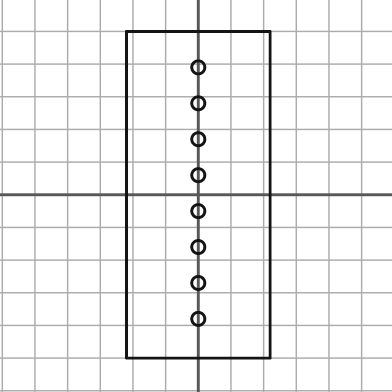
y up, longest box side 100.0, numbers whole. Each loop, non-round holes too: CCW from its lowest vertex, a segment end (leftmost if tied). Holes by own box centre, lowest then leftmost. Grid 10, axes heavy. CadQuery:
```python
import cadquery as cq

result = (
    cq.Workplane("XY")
    .moveTo(-22.0, -50.0)
    .lineTo(22.0, -50.0)
    .lineTo(22.0, 50.0)
    .lineTo(-22.0, 50.0)
    .close()
    .moveTo(0.0, -38.0)
    .circle(2.0)
    .moveTo(0.0, -27.0)
    .circle(2.0)
    .moveTo(0.0, -16.0)
    .circle(2.0)
    .moveTo(0.0, -5.0)
    .circle(2.0)
    .moveTo(0.0, 6.0)
    .circle(2.0)
    .moveTo(0.0, 17.0)
    .circle(2.0)
    .moveTo(0.0, 28.0)
    .circle(2.0)
    .moveTo(0.0, 39.0)
    .circle(2.0)
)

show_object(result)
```